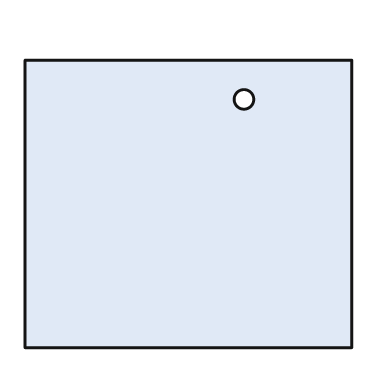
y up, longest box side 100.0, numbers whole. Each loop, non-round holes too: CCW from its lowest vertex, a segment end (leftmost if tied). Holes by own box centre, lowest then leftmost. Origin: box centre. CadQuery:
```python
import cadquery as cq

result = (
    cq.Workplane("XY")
    .moveTo(-50.0, -44.0)
    .lineTo(50.0, -44.0)
    .lineTo(50.0, 44.0)
    .lineTo(-50.0, 44.0)
    .close()
    .moveTo(17.0, 32.0)
    .circle(3.0)
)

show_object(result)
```